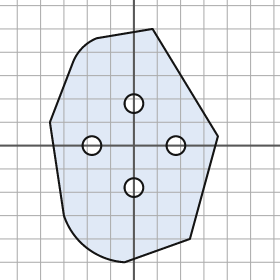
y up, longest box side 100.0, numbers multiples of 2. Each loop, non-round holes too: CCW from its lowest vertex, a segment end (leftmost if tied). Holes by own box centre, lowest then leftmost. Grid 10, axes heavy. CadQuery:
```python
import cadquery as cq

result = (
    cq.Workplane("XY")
    .moveTo(-4.0, -50.0)
    .lineTo(24.0, -40.0)
    .lineTo(36.0, 4.0)
    .lineTo(8.0, 50.0)
    .lineTo(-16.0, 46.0)
    .threePointArc((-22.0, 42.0), (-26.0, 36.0))
    .lineTo(-36.0, 10.0)
    .lineTo(-30.0, -30.0)
    .threePointArc((-20.0, -44.0), (-4.0, -50.0))
    .close()
    .moveTo(0.0, -18.0)
    .circle(4.0)
    .moveTo(-18.0, 0.0)
    .circle(4.0)
    .moveTo(18.0, 0.0)
    .circle(4.0)
    .moveTo(0.0, 18.0)
    .circle(4.0)
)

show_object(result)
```